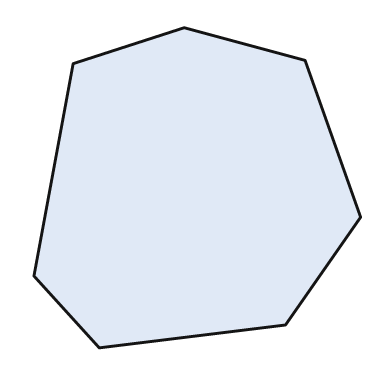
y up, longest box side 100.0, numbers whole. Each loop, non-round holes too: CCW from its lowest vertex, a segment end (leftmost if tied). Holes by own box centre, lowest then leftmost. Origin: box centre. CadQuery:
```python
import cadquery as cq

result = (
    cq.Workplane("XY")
    .moveTo(-30.0, -49.0)
    .lineTo(27.0, -42.0)
    .lineTo(50.0, -9.0)
    .lineTo(33.0, 39.0)
    .lineTo(-4.0, 49.0)
    .lineTo(-38.0, 38.0)
    .lineTo(-50.0, -27.0)
    .close()
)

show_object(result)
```